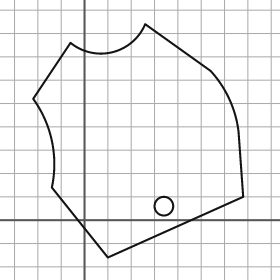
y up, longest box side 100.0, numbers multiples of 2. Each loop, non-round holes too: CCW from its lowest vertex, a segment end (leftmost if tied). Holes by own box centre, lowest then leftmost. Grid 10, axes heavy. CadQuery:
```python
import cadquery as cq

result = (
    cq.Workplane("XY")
    .moveTo(10.0, -16.0)
    .lineTo(68.0, 10.0)
    .lineTo(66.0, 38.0)
    .threePointArc((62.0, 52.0), (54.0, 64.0))
    .lineTo(26.0, 84.0)
    .threePointArc((12.0, 72.0), (-6.0, 76.0))
    .lineTo(-22.0, 52.0)
    .threePointArc((-14.0, 34.0), (-14.0, 14.0))
    .close()
    .moveTo(34.0, 6.0)
    .circle(4.0)
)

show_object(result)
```